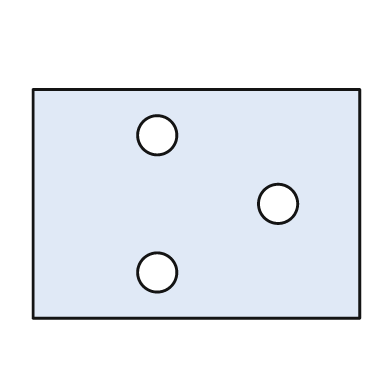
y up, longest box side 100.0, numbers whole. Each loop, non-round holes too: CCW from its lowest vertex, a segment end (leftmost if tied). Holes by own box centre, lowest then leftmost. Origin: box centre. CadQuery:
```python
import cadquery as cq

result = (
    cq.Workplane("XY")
    .moveTo(-50.0, -35.0)
    .lineTo(50.0, -35.0)
    .lineTo(50.0, 35.0)
    .lineTo(-50.0, 35.0)
    .close()
    .moveTo(-12.0, -21.0)
    .circle(6.0)
    .moveTo(25.0, 0.0)
    .circle(6.0)
    .moveTo(-12.0, 21.0)
    .circle(6.0)
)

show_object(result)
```